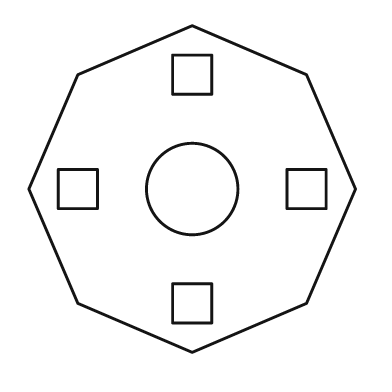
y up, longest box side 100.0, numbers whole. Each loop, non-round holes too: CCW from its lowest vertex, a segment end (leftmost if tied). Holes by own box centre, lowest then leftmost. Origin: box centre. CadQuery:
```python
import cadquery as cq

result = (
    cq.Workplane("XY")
    .moveTo(0.0, -50.0)
    .lineTo(35.0, -35.0)
    .lineTo(50.0, 0.0)
    .lineTo(35.0, 35.0)
    .lineTo(0.0, 50.0)
    .lineTo(-35.0, 35.0)
    .lineTo(-50.0, 0.0)
    .lineTo(-35.0, -35.0)
    .close()
    .moveTo(-6.0, -41.0)
    .lineTo(6.0, -41.0)
    .lineTo(6.0, -29.0)
    .lineTo(-6.0, -29.0)
    .close()
    .moveTo(-41.0, -6.0)
    .lineTo(-29.0, -6.0)
    .lineTo(-29.0, 6.0)
    .lineTo(-41.0, 6.0)
    .close()
    .moveTo(0.0, 0.0)
    .circle(14.0)
    .moveTo(29.0, -6.0)
    .lineTo(41.0, -6.0)
    .lineTo(41.0, 6.0)
    .lineTo(29.0, 6.0)
    .close()
    .moveTo(-6.0, 29.0)
    .lineTo(6.0, 29.0)
    .lineTo(6.0, 41.0)
    .lineTo(-6.0, 41.0)
    .close()
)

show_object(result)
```